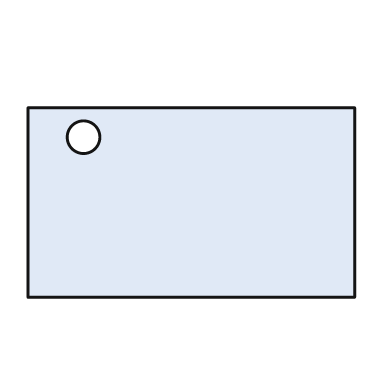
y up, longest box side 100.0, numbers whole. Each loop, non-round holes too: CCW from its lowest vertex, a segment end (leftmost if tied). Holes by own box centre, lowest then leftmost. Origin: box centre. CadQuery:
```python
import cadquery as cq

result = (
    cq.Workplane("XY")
    .moveTo(-50.0, -29.0)
    .lineTo(50.0, -29.0)
    .lineTo(50.0, 29.0)
    .lineTo(-50.0, 29.0)
    .close()
    .moveTo(-33.0, 20.0)
    .circle(5.0)
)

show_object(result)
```